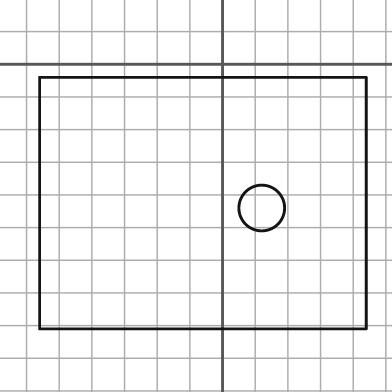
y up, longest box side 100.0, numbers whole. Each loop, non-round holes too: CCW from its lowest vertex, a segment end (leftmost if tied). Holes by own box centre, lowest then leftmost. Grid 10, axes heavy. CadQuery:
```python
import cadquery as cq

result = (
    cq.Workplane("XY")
    .moveTo(-56.0, -81.0)
    .lineTo(44.0, -81.0)
    .lineTo(44.0, -4.0)
    .lineTo(-56.0, -4.0)
    .close()
    .moveTo(12.0, -44.0)
    .circle(7.0)
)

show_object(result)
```